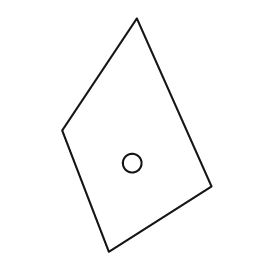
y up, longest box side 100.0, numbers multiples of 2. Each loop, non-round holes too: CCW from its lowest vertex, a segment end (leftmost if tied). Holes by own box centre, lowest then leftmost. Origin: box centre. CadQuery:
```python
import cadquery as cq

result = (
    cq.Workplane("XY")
    .moveTo(-12.0, -50.0)
    .lineTo(32.0, -22.0)
    .lineTo(0.0, 50.0)
    .lineTo(-32.0, 2.0)
    .close()
    .moveTo(-2.0, -12.0)
    .circle(4.0)
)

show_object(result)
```